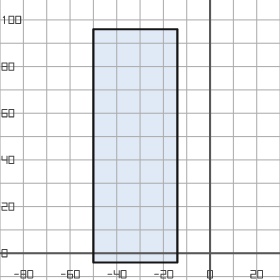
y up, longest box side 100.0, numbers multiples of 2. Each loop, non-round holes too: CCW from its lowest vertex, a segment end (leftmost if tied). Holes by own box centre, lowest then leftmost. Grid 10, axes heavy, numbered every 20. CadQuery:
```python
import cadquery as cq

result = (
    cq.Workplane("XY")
    .moveTo(-50.0, -4.0)
    .lineTo(-14.0, -4.0)
    .lineTo(-14.0, 96.0)
    .lineTo(-50.0, 96.0)
    .close()
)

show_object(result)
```